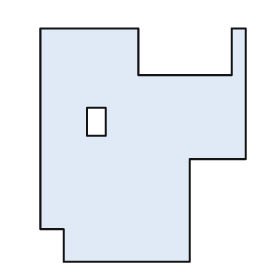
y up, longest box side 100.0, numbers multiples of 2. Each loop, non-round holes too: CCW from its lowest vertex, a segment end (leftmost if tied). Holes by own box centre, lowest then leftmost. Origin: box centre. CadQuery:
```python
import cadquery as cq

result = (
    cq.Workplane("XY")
    .moveTo(-34.0, -50.0)
    .lineTo(20.0, -50.0)
    .lineTo(20.0, -6.0)
    .lineTo(44.0, -6.0)
    .lineTo(44.0, 50.0)
    .lineTo(38.0, 50.0)
    .lineTo(38.0, 30.0)
    .lineTo(-2.0, 30.0)
    .lineTo(-2.0, 50.0)
    .lineTo(-44.0, 50.0)
    .lineTo(-44.0, -36.0)
    .lineTo(-34.0, -36.0)
    .close()
    .moveTo(-24.0, 4.0)
    .lineTo(-16.0, 4.0)
    .lineTo(-16.0, 16.0)
    .lineTo(-24.0, 16.0)
    .close()
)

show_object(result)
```